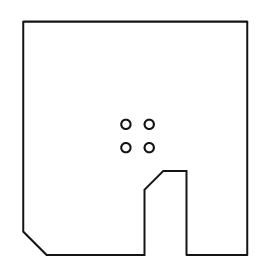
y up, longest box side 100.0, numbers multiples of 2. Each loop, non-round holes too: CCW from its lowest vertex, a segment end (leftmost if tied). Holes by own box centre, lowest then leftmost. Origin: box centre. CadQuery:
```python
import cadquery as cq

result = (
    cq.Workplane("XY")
    .moveTo(-38.0, -50.0)
    .lineTo(4.0, -50.0)
    .lineTo(4.0, -22.0)
    .lineTo(12.0, -14.0)
    .lineTo(22.0, -14.0)
    .lineTo(22.0, -50.0)
    .lineTo(48.0, -50.0)
    .lineTo(48.0, 50.0)
    .lineTo(-48.0, 50.0)
    .lineTo(-48.0, -40.0)
    .close()
    .moveTo(-4.0, -4.0)
    .circle(2.0)
    .moveTo(6.0, -4.0)
    .circle(2.0)
    .moveTo(-4.0, 6.0)
    .circle(2.0)
    .moveTo(6.0, 6.0)
    .circle(2.0)
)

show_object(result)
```